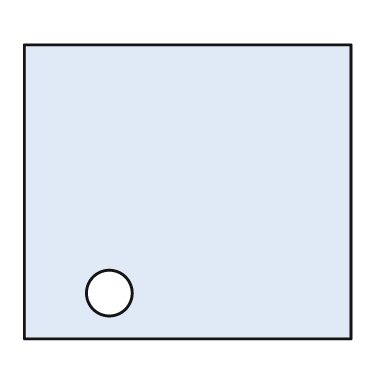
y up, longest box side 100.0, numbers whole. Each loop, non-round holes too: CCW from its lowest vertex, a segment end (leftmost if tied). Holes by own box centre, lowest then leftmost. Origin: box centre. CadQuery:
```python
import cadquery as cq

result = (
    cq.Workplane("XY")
    .moveTo(-50.0, -45.0)
    .lineTo(50.0, -45.0)
    .lineTo(50.0, 45.0)
    .lineTo(-50.0, 45.0)
    .close()
    .moveTo(-24.0, -31.0)
    .circle(7.0)
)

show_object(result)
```